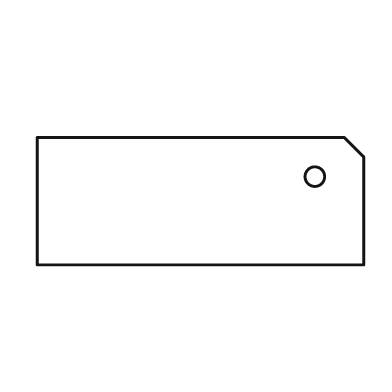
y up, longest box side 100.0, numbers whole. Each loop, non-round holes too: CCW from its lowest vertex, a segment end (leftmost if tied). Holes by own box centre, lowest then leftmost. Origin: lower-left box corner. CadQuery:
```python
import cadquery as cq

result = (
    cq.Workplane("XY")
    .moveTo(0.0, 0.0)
    .lineTo(100.0, 0.0)
    .lineTo(100.0, 33.0)
    .lineTo(94.0, 39.0)
    .lineTo(0.0, 39.0)
    .close()
    .moveTo(85.0, 27.0)
    .circle(3.0)
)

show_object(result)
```